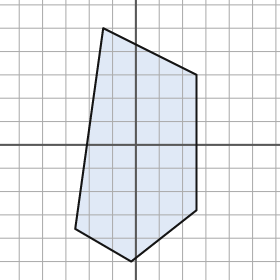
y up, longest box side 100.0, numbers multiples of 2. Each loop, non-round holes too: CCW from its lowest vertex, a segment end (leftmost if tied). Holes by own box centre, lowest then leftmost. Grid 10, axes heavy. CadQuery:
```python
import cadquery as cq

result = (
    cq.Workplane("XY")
    .moveTo(-2.0, -50.0)
    .lineTo(26.0, -28.0)
    .lineTo(26.0, 30.0)
    .lineTo(-14.0, 50.0)
    .lineTo(-26.0, -36.0)
    .close()
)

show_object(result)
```